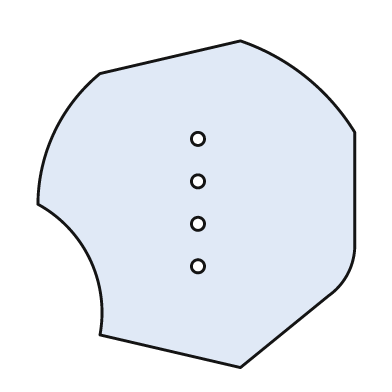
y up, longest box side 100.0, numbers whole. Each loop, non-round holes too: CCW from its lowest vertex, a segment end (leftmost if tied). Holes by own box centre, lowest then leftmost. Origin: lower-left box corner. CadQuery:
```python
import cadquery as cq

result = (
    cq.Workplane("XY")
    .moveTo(62.0, 0.0)
    .lineTo(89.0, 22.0)
    .threePointArc((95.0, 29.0), (97.0, 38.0))
    .lineTo(97.0, 72.0)
    .threePointArc((82.0, 89.0), (62.0, 100.0))
    .lineTo(19.0, 90.0)
    .threePointArc((5.0, 72.0), (0.0, 50.0))
    .threePointArc((16.0, 33.0), (19.0, 10.0))
    .close()
    .moveTo(49.0, 31.0)
    .circle(2.0)
    .moveTo(49.0, 44.0)
    .circle(2.0)
    .moveTo(49.0, 57.0)
    .circle(2.0)
    .moveTo(49.0, 70.0)
    .circle(2.0)
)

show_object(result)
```